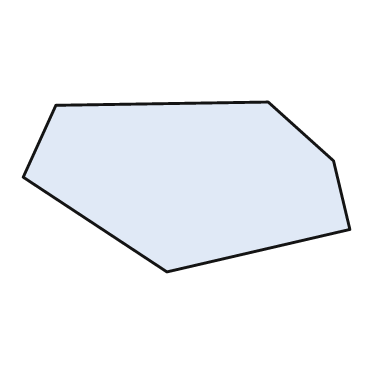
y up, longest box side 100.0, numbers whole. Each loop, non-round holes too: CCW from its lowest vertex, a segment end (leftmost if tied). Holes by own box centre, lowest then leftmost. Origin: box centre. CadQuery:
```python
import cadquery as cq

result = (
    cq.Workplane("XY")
    .moveTo(-6.0, -26.0)
    .lineTo(50.0, -13.0)
    .lineTo(45.0, 8.0)
    .lineTo(25.0, 26.0)
    .lineTo(-40.0, 25.0)
    .lineTo(-50.0, 3.0)
    .close()
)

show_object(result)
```